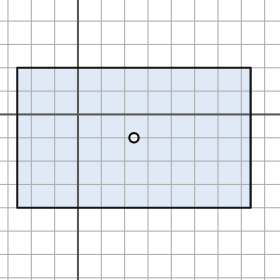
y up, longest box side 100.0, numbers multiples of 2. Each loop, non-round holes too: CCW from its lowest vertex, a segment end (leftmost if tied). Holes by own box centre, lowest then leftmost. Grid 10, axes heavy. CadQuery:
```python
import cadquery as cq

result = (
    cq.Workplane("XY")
    .moveTo(-26.0, -40.0)
    .lineTo(74.0, -40.0)
    .lineTo(74.0, 20.0)
    .lineTo(-26.0, 20.0)
    .close()
    .moveTo(24.0, -10.0)
    .circle(2.0)
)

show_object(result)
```